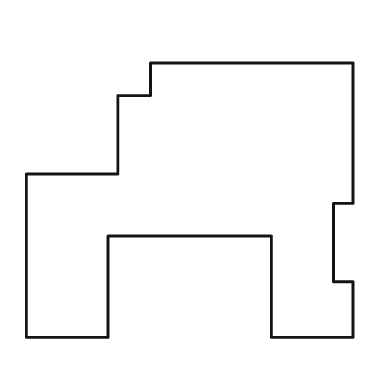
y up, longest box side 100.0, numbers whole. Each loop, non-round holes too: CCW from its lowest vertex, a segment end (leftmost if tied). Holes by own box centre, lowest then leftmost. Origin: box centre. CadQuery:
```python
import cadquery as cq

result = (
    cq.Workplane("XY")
    .moveTo(-50.0, -42.0)
    .lineTo(-25.0, -42.0)
    .lineTo(-25.0, -11.0)
    .lineTo(25.0, -11.0)
    .lineTo(25.0, -42.0)
    .lineTo(50.0, -42.0)
    .lineTo(50.0, -25.0)
    .lineTo(44.0, -25.0)
    .lineTo(44.0, -1.0)
    .lineTo(50.0, -1.0)
    .lineTo(50.0, 42.0)
    .lineTo(-12.0, 42.0)
    .lineTo(-12.0, 32.0)
    .lineTo(-22.0, 32.0)
    .lineTo(-22.0, 8.0)
    .lineTo(-50.0, 8.0)
    .close()
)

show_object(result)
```